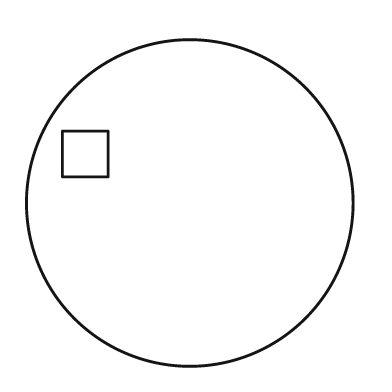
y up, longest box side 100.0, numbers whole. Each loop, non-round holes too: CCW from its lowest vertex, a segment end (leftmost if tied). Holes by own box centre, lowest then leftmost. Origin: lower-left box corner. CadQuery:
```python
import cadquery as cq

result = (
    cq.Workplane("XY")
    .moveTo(50.0, 50.0)
    .circle(50.0)
    .moveTo(11.0, 58.0)
    .lineTo(25.0, 58.0)
    .lineTo(25.0, 72.0)
    .lineTo(11.0, 72.0)
    .close()
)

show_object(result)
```